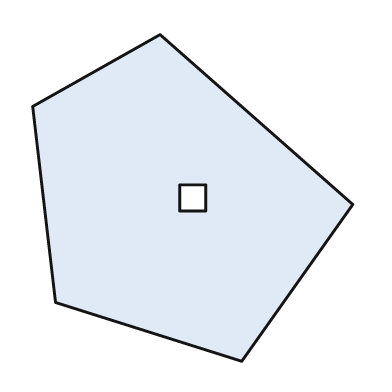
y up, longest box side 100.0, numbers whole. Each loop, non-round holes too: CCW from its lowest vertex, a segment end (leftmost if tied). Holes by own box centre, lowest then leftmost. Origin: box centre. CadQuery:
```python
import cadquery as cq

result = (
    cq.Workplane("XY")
    .moveTo(15.0, -50.0)
    .lineTo(49.0, -2.0)
    .lineTo(-10.0, 50.0)
    .lineTo(-49.0, 28.0)
    .lineTo(-42.0, -32.0)
    .close()
    .moveTo(-4.0, -4.0)
    .lineTo(4.0, -4.0)
    .lineTo(4.0, 4.0)
    .lineTo(-4.0, 4.0)
    .close()
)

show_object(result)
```